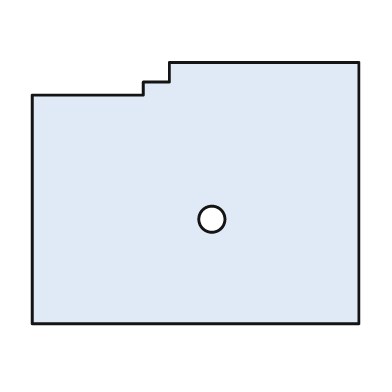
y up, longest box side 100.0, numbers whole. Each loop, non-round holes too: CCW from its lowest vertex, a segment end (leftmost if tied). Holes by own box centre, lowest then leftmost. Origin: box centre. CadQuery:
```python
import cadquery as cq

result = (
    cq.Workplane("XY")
    .moveTo(-50.0, -40.0)
    .lineTo(50.0, -40.0)
    .lineTo(50.0, 40.0)
    .lineTo(-8.0, 40.0)
    .lineTo(-8.0, 34.0)
    .lineTo(-16.0, 34.0)
    .lineTo(-16.0, 30.0)
    .lineTo(-50.0, 30.0)
    .close()
    .moveTo(5.0, -8.0)
    .circle(4.0)
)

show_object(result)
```